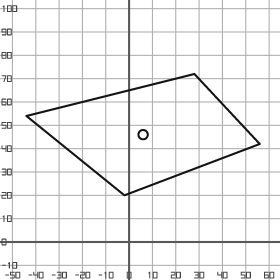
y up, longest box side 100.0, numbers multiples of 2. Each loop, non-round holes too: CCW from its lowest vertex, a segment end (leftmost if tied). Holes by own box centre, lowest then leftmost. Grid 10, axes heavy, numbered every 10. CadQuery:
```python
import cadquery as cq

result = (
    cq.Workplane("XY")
    .moveTo(-2.0, 20.0)
    .lineTo(56.0, 42.0)
    .lineTo(28.0, 72.0)
    .lineTo(-44.0, 54.0)
    .close()
    .moveTo(6.0, 46.0)
    .circle(2.0)
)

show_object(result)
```